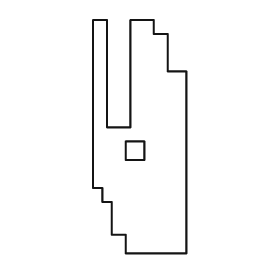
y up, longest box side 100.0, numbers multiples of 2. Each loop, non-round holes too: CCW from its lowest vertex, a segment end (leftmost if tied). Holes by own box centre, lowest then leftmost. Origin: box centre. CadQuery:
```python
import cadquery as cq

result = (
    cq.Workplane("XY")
    .moveTo(-6.0, -50.0)
    .lineTo(20.0, -50.0)
    .lineTo(20.0, 28.0)
    .lineTo(12.0, 28.0)
    .lineTo(12.0, 44.0)
    .lineTo(6.0, 44.0)
    .lineTo(6.0, 50.0)
    .lineTo(-4.0, 50.0)
    .lineTo(-4.0, 4.0)
    .lineTo(-14.0, 4.0)
    .lineTo(-14.0, 50.0)
    .lineTo(-20.0, 50.0)
    .lineTo(-20.0, -22.0)
    .lineTo(-16.0, -22.0)
    .lineTo(-16.0, -28.0)
    .lineTo(-12.0, -28.0)
    .lineTo(-12.0, -42.0)
    .lineTo(-6.0, -42.0)
    .close()
    .moveTo(-6.0, -10.0)
    .lineTo(2.0, -10.0)
    .lineTo(2.0, -2.0)
    .lineTo(-6.0, -2.0)
    .close()
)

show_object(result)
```